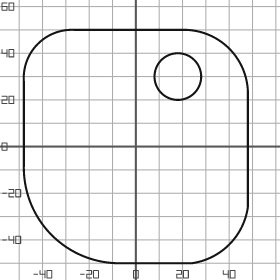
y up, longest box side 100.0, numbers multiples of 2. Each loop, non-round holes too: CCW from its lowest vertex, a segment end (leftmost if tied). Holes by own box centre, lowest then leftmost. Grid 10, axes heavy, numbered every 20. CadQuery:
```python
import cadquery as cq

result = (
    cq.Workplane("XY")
    .moveTo(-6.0, -50.0)
    .lineTo(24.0, -50.0)
    .threePointArc((40.0, -42.0), (48.0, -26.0))
    .lineTo(48.0, 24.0)
    .threePointArc((40.0, 42.0), (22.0, 50.0))
    .lineTo(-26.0, 50.0)
    .threePointArc((-42.0, 44.0), (-48.0, 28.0))
    .lineTo(-48.0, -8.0)
    .threePointArc((-36.0, -38.0), (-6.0, -50.0))
    .close()
    .moveTo(18.0, 30.0)
    .circle(10.0)
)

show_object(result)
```